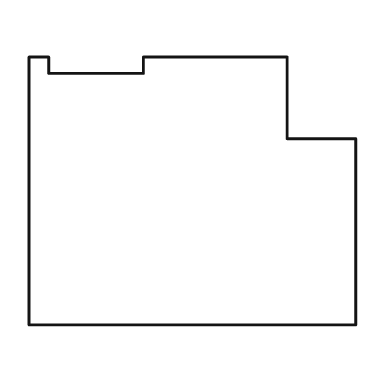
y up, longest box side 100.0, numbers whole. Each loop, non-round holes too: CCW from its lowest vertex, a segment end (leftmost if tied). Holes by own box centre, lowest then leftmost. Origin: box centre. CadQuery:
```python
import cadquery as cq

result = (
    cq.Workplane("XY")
    .moveTo(-50.0, -41.0)
    .lineTo(50.0, -41.0)
    .lineTo(50.0, 16.0)
    .lineTo(29.0, 16.0)
    .lineTo(29.0, 41.0)
    .lineTo(-15.0, 41.0)
    .lineTo(-15.0, 36.0)
    .lineTo(-44.0, 36.0)
    .lineTo(-44.0, 41.0)
    .lineTo(-50.0, 41.0)
    .close()
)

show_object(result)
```